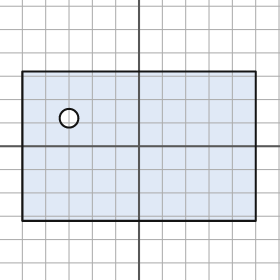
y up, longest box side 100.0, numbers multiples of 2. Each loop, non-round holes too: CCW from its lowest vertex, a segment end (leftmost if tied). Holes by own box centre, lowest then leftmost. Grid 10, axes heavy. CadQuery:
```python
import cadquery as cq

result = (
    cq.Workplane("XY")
    .moveTo(-50.0, -32.0)
    .lineTo(50.0, -32.0)
    .lineTo(50.0, 32.0)
    .lineTo(-50.0, 32.0)
    .close()
    .moveTo(-30.0, 12.0)
    .circle(4.0)
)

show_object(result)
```